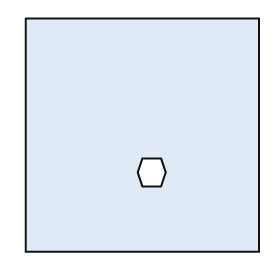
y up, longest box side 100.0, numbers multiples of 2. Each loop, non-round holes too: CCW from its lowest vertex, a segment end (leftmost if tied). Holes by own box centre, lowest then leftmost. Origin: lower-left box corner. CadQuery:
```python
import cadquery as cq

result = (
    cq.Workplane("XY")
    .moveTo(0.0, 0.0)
    .lineTo(100.0, 0.0)
    .lineTo(100.0, 100.0)
    .lineTo(0.0, 100.0)
    .close()
    .moveTo(50.0, 28.0)
    .lineTo(58.0, 28.0)
    .lineTo(60.0, 34.0)
    .lineTo(58.0, 40.0)
    .lineTo(50.0, 40.0)
    .lineTo(48.0, 34.0)
    .close()
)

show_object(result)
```